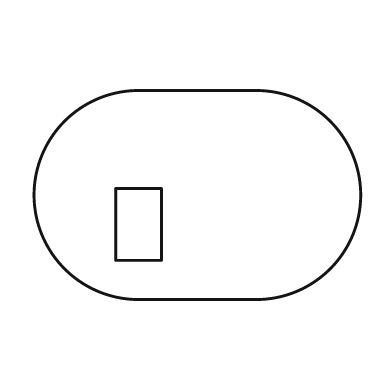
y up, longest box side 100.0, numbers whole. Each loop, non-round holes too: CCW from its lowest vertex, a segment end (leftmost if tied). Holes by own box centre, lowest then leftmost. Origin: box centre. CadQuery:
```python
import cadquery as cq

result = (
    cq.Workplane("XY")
    .moveTo(-18.0, -32.0)
    .lineTo(18.0, -32.0)
    .threePointArc((50.0, 0.0), (18.0, 32.0))
    .lineTo(-18.0, 32.0)
    .threePointArc((-50.0, 0.0), (-18.0, -32.0))
    .close()
    .moveTo(-25.0, -20.0)
    .lineTo(-11.0, -20.0)
    .lineTo(-11.0, 2.0)
    .lineTo(-25.0, 2.0)
    .close()
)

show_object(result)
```